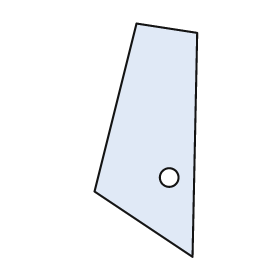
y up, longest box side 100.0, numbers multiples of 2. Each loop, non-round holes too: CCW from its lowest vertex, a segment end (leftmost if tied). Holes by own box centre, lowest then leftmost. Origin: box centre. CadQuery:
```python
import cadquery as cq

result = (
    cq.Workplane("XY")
    .moveTo(20.0, -50.0)
    .lineTo(22.0, 46.0)
    .lineTo(-4.0, 50.0)
    .lineTo(-22.0, -22.0)
    .close()
    .moveTo(10.0, -16.0)
    .circle(4.0)
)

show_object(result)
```